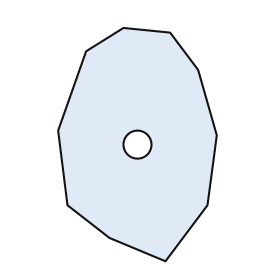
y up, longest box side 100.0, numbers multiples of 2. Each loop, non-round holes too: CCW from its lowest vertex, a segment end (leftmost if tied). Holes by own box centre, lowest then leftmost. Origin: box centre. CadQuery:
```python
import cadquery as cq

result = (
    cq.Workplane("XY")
    .moveTo(12.0, -50.0)
    .lineTo(30.0, -26.0)
    .lineTo(34.0, 4.0)
    .lineTo(26.0, 32.0)
    .lineTo(14.0, 48.0)
    .lineTo(-6.0, 50.0)
    .lineTo(-22.0, 40.0)
    .lineTo(-34.0, 6.0)
    .lineTo(-30.0, -26.0)
    .lineTo(-12.0, -40.0)
    .close()
    .moveTo(0.0, 0.0)
    .circle(6.0)
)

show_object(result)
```